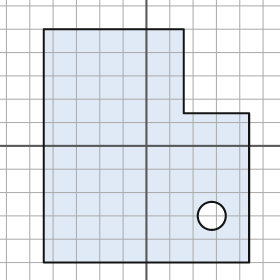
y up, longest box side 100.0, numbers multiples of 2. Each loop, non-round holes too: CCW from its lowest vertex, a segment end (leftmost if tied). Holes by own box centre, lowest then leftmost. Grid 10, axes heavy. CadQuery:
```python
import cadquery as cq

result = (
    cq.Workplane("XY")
    .moveTo(-44.0, -50.0)
    .lineTo(44.0, -50.0)
    .lineTo(44.0, 14.0)
    .lineTo(16.0, 14.0)
    .lineTo(16.0, 50.0)
    .lineTo(-44.0, 50.0)
    .close()
    .moveTo(28.0, -30.0)
    .circle(6.0)
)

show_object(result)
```